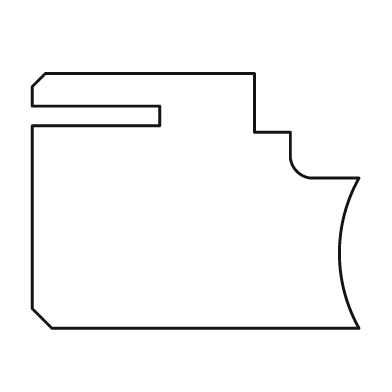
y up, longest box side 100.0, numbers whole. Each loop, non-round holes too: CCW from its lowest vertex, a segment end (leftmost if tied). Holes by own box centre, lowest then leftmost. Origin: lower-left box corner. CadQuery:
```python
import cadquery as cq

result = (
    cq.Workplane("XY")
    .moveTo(6.0, 0.0)
    .lineTo(100.0, 0.0)
    .threePointArc((94.0, 23.0), (100.0, 46.0))
    .lineTo(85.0, 46.0)
    .threePointArc((81.0, 48.0), (79.0, 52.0))
    .lineTo(79.0, 60.0)
    .lineTo(68.0, 60.0)
    .lineTo(68.0, 78.0)
    .lineTo(4.0, 78.0)
    .lineTo(0.0, 74.0)
    .lineTo(0.0, 68.0)
    .lineTo(39.0, 68.0)
    .lineTo(39.0, 62.0)
    .lineTo(0.0, 62.0)
    .lineTo(0.0, 6.0)
    .close()
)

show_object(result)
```